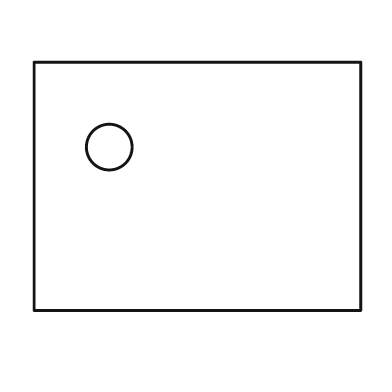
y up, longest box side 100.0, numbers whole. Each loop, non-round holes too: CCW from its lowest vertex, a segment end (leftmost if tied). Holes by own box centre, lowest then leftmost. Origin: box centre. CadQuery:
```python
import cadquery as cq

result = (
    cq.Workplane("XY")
    .moveTo(-50.0, -38.0)
    .lineTo(50.0, -38.0)
    .lineTo(50.0, 38.0)
    .lineTo(-50.0, 38.0)
    .close()
    .moveTo(-27.0, 12.0)
    .circle(7.0)
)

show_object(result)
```